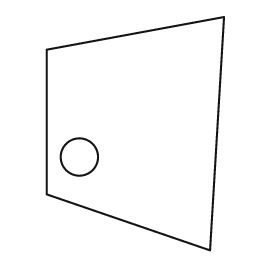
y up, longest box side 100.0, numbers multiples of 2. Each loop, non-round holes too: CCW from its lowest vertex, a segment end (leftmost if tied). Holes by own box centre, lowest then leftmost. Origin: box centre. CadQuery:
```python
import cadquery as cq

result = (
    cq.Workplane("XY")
    .moveTo(32.0, -50.0)
    .lineTo(38.0, 50.0)
    .lineTo(-38.0, 36.0)
    .lineTo(-38.0, -26.0)
    .close()
    .moveTo(-24.0, -10.0)
    .circle(8.0)
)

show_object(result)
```